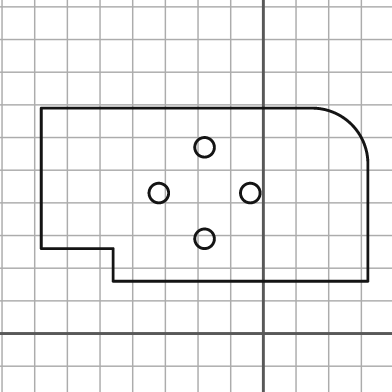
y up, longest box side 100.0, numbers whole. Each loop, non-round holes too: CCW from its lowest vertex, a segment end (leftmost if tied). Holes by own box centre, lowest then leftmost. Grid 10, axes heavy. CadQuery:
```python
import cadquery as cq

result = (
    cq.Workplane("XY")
    .moveTo(-46.0, 16.0)
    .lineTo(32.0, 16.0)
    .lineTo(32.0, 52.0)
    .threePointArc((27.0, 64.0), (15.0, 69.0))
    .lineTo(-68.0, 69.0)
    .lineTo(-68.0, 26.0)
    .lineTo(-46.0, 26.0)
    .close()
    .moveTo(-18.0, 29.0)
    .circle(3.0)
    .moveTo(-32.0, 43.0)
    .circle(3.0)
    .moveTo(-4.0, 43.0)
    .circle(3.0)
    .moveTo(-18.0, 57.0)
    .circle(3.0)
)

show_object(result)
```